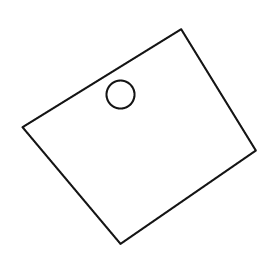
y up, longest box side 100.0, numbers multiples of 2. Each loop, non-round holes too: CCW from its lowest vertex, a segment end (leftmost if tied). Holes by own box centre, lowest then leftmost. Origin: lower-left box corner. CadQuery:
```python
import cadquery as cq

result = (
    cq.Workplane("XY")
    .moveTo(42.0, 0.0)
    .lineTo(100.0, 40.0)
    .lineTo(68.0, 92.0)
    .lineTo(0.0, 50.0)
    .close()
    .moveTo(42.0, 64.0)
    .circle(6.0)
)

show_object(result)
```